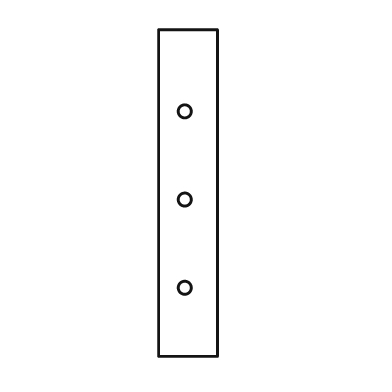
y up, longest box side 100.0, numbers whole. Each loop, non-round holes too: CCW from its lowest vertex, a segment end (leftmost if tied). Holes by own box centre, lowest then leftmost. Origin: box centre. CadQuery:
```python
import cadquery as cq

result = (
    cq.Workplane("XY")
    .moveTo(-9.0, -50.0)
    .lineTo(9.0, -50.0)
    .lineTo(9.0, 50.0)
    .lineTo(-9.0, 50.0)
    .close()
    .moveTo(-1.0, -29.0)
    .circle(2.0)
    .moveTo(-1.0, -2.0)
    .circle(2.0)
    .moveTo(-1.0, 25.0)
    .circle(2.0)
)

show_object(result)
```